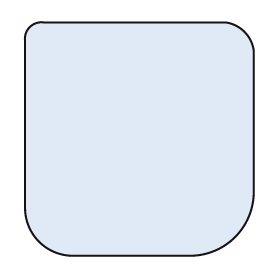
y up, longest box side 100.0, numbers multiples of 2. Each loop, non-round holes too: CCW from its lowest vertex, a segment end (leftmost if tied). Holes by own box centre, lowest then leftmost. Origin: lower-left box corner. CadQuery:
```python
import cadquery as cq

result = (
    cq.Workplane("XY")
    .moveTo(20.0, 0.0)
    .lineTo(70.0, 0.0)
    .threePointArc((90.0, 8.0), (98.0, 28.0))
    .lineTo(98.0, 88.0)
    .threePointArc((94.0, 96.0), (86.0, 100.0))
    .lineTo(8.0, 100.0)
    .threePointArc((2.0, 98.0), (0.0, 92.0))
    .lineTo(0.0, 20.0)
    .threePointArc((6.0, 6.0), (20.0, 0.0))
    .close()
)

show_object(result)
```